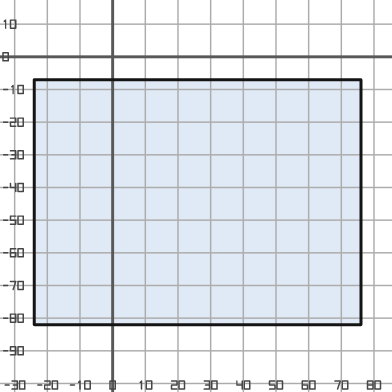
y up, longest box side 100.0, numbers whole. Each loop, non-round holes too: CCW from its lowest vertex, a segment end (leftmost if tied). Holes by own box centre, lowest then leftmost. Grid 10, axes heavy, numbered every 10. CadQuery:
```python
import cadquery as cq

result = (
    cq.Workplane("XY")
    .moveTo(-24.0, -82.0)
    .lineTo(76.0, -82.0)
    .lineTo(76.0, -7.0)
    .lineTo(-24.0, -7.0)
    .close()
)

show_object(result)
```